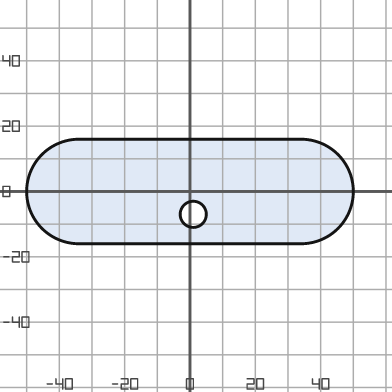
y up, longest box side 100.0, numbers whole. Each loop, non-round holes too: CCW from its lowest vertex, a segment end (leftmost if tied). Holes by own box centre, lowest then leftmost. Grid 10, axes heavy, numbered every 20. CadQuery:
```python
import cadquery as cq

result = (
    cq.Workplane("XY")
    .moveTo(-34.0, -16.0)
    .lineTo(34.0, -16.0)
    .threePointArc((50.0, 0.0), (34.0, 16.0))
    .lineTo(-34.0, 16.0)
    .threePointArc((-50.0, 0.0), (-34.0, -16.0))
    .close()
    .moveTo(1.0, -7.0)
    .circle(4.0)
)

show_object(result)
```